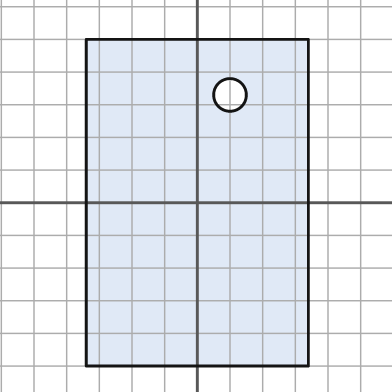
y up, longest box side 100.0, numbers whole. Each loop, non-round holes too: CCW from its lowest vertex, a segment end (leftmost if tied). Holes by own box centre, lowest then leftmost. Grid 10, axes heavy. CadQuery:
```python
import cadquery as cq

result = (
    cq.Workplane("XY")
    .moveTo(-34.0, -50.0)
    .lineTo(34.0, -50.0)
    .lineTo(34.0, 50.0)
    .lineTo(-34.0, 50.0)
    .close()
    .moveTo(10.0, 33.0)
    .circle(5.0)
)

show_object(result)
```